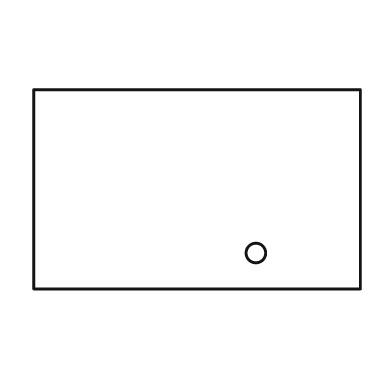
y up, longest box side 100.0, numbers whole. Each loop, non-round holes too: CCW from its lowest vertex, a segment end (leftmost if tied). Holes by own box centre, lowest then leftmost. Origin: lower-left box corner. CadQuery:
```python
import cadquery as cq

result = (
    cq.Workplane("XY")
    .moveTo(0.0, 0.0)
    .lineTo(100.0, 0.0)
    .lineTo(100.0, 61.0)
    .lineTo(0.0, 61.0)
    .close()
    .moveTo(68.0, 11.0)
    .circle(3.0)
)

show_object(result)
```